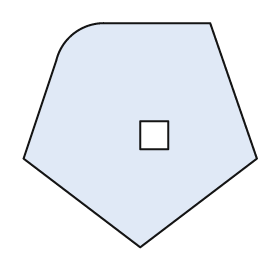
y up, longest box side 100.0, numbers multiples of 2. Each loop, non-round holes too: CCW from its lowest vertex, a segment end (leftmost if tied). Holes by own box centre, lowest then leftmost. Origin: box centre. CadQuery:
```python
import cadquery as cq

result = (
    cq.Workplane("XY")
    .moveTo(0.0, -48.0)
    .lineTo(50.0, -10.0)
    .lineTo(30.0, 48.0)
    .lineTo(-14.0, 48.0)
    .threePointArc((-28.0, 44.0), (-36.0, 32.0))
    .lineTo(-50.0, -10.0)
    .close()
    .moveTo(0.0, -6.0)
    .lineTo(12.0, -6.0)
    .lineTo(12.0, 6.0)
    .lineTo(0.0, 6.0)
    .close()
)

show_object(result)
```